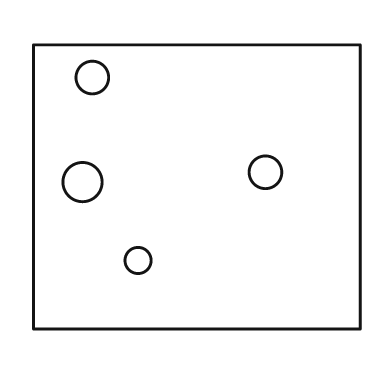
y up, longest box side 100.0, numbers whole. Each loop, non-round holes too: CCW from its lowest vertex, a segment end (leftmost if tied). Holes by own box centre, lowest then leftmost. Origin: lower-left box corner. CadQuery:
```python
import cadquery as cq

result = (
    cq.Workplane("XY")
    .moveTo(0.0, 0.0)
    .lineTo(100.0, 0.0)
    .lineTo(100.0, 87.0)
    .lineTo(0.0, 87.0)
    .close()
    .moveTo(32.0, 21.0)
    .circle(4.0)
    .moveTo(15.0, 45.0)
    .circle(6.0)
    .moveTo(71.0, 48.0)
    .circle(5.0)
    .moveTo(18.0, 77.0)
    .circle(5.0)
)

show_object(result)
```